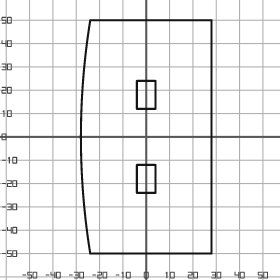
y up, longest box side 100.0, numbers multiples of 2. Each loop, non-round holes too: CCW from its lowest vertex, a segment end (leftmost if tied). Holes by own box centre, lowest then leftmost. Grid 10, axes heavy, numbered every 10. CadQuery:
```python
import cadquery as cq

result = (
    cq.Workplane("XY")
    .moveTo(-24.0, -50.0)
    .lineTo(28.0, -50.0)
    .lineTo(28.0, 50.0)
    .lineTo(-24.0, 50.0)
    .threePointArc((-28.0, 0.0), (-24.0, -50.0))
    .close()
    .moveTo(-4.0, -24.0)
    .lineTo(4.0, -24.0)
    .lineTo(4.0, -12.0)
    .lineTo(-4.0, -12.0)
    .close()
    .moveTo(-4.0, 12.0)
    .lineTo(4.0, 12.0)
    .lineTo(4.0, 24.0)
    .lineTo(-4.0, 24.0)
    .close()
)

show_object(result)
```